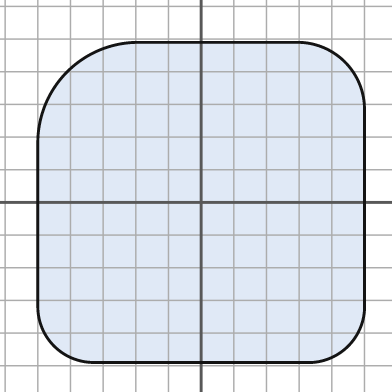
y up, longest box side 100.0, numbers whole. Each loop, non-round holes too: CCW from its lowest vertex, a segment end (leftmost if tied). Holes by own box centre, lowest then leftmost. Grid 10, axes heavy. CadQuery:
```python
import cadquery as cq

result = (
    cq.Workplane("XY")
    .moveTo(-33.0, -49.0)
    .lineTo(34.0, -49.0)
    .threePointArc((45.0, -44.0), (50.0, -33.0))
    .lineTo(50.0, 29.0)
    .threePointArc((44.0, 43.0), (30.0, 49.0))
    .lineTo(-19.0, 49.0)
    .threePointArc((-41.0, 40.0), (-50.0, 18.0))
    .lineTo(-50.0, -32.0)
    .threePointArc((-45.0, -44.0), (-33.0, -49.0))
    .close()
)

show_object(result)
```